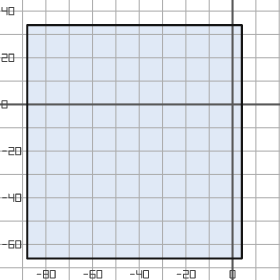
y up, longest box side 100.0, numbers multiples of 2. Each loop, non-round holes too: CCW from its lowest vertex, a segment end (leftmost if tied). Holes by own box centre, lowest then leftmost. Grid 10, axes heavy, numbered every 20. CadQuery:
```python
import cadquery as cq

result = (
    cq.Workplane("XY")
    .moveTo(-88.0, -66.0)
    .lineTo(4.0, -66.0)
    .lineTo(4.0, 34.0)
    .lineTo(-88.0, 34.0)
    .close()
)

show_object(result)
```